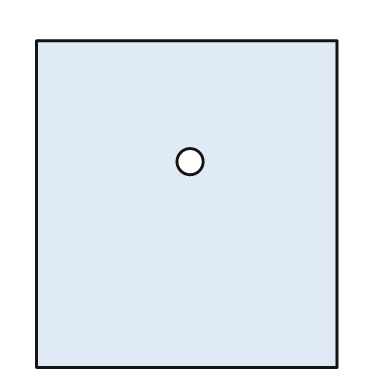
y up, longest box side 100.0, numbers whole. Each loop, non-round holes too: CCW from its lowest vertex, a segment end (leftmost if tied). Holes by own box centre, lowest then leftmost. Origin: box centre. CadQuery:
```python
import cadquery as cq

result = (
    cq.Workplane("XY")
    .moveTo(-46.0, -50.0)
    .lineTo(46.0, -50.0)
    .lineTo(46.0, 50.0)
    .lineTo(-46.0, 50.0)
    .close()
    .moveTo(1.0, 13.0)
    .circle(4.0)
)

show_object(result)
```